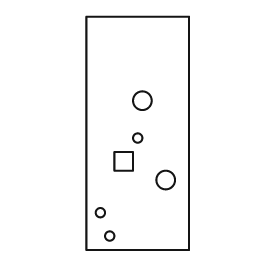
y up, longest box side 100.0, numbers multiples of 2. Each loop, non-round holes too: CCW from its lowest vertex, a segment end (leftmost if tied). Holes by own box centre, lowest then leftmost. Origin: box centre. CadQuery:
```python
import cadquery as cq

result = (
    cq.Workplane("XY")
    .moveTo(-22.0, -50.0)
    .lineTo(22.0, -50.0)
    .lineTo(22.0, 50.0)
    .lineTo(-22.0, 50.0)
    .close()
    .moveTo(-12.0, -44.0)
    .circle(2.0)
    .moveTo(-16.0, -34.0)
    .circle(2.0)
    .moveTo(12.0, -20.0)
    .circle(4.0)
    .moveTo(-10.0, -16.0)
    .lineTo(-2.0, -16.0)
    .lineTo(-2.0, -8.0)
    .lineTo(-10.0, -8.0)
    .close()
    .moveTo(0.0, -2.0)
    .circle(2.0)
    .moveTo(2.0, 14.0)
    .circle(4.0)
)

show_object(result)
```